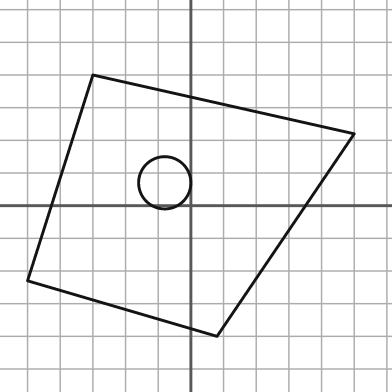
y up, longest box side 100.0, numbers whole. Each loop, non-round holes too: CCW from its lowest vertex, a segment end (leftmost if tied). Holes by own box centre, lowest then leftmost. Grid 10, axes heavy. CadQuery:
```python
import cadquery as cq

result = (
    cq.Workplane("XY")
    .moveTo(8.0, -40.0)
    .lineTo(50.0, 22.0)
    .lineTo(-30.0, 40.0)
    .lineTo(-50.0, -23.0)
    .close()
    .moveTo(-8.0, 7.0)
    .circle(8.0)
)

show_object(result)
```